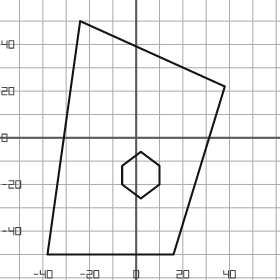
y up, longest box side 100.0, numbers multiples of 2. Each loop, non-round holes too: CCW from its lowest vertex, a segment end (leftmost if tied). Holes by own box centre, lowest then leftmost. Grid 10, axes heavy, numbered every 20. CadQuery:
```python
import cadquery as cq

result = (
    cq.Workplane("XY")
    .moveTo(-38.0, -50.0)
    .lineTo(16.0, -50.0)
    .lineTo(38.0, 22.0)
    .lineTo(-24.0, 50.0)
    .close()
    .moveTo(2.0, -26.0)
    .lineTo(10.0, -20.0)
    .lineTo(10.0, -12.0)
    .lineTo(2.0, -6.0)
    .lineTo(-6.0, -12.0)
    .lineTo(-6.0, -20.0)
    .close()
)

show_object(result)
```